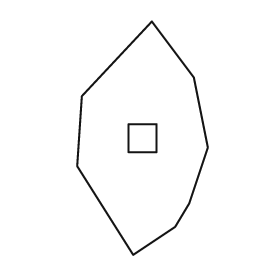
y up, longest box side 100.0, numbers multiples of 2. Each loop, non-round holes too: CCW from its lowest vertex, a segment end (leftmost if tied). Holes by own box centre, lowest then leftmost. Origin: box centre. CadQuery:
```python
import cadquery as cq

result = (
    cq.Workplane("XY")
    .moveTo(-4.0, -50.0)
    .lineTo(14.0, -38.0)
    .lineTo(20.0, -28.0)
    .lineTo(28.0, -4.0)
    .lineTo(22.0, 26.0)
    .lineTo(4.0, 50.0)
    .lineTo(-26.0, 18.0)
    .lineTo(-28.0, -12.0)
    .close()
    .moveTo(-6.0, -6.0)
    .lineTo(6.0, -6.0)
    .lineTo(6.0, 6.0)
    .lineTo(-6.0, 6.0)
    .close()
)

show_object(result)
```